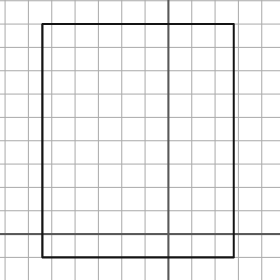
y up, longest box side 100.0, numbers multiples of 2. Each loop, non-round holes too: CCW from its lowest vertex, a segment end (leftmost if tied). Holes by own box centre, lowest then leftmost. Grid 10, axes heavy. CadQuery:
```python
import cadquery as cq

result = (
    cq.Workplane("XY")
    .moveTo(-54.0, -10.0)
    .lineTo(28.0, -10.0)
    .lineTo(28.0, 90.0)
    .lineTo(-54.0, 90.0)
    .close()
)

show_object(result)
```